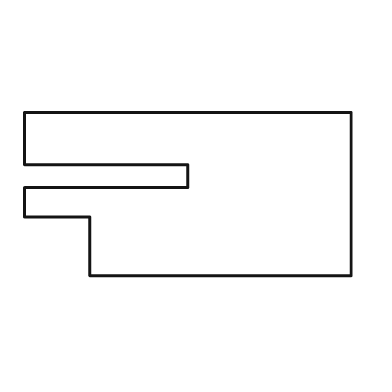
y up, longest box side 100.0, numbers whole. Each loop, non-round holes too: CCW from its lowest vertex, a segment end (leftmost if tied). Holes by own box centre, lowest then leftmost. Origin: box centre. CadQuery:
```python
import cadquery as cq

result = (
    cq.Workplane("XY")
    .moveTo(-30.0, -25.0)
    .lineTo(50.0, -25.0)
    .lineTo(50.0, 25.0)
    .lineTo(-50.0, 25.0)
    .lineTo(-50.0, 9.0)
    .lineTo(0.0, 9.0)
    .lineTo(0.0, 2.0)
    .lineTo(-50.0, 2.0)
    .lineTo(-50.0, -7.0)
    .lineTo(-30.0, -7.0)
    .close()
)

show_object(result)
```